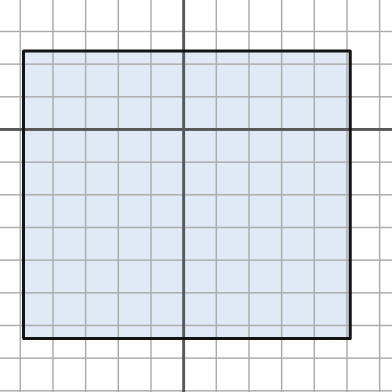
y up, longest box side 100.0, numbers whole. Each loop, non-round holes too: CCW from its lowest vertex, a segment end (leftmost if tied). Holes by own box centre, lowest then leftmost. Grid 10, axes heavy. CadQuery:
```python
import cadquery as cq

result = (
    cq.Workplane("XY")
    .moveTo(-49.0, -64.0)
    .lineTo(51.0, -64.0)
    .lineTo(51.0, 24.0)
    .lineTo(-49.0, 24.0)
    .close()
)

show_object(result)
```